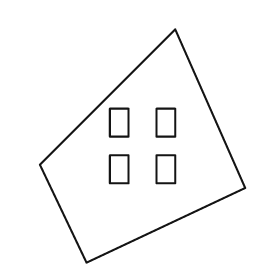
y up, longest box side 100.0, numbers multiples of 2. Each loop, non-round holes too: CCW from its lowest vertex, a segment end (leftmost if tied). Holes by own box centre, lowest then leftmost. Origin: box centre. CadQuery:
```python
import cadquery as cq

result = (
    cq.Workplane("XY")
    .moveTo(-24.0, -50.0)
    .lineTo(44.0, -18.0)
    .lineTo(14.0, 50.0)
    .lineTo(-44.0, -8.0)
    .close()
    .moveTo(-14.0, -16.0)
    .lineTo(-6.0, -16.0)
    .lineTo(-6.0, -4.0)
    .lineTo(-14.0, -4.0)
    .close()
    .moveTo(6.0, -16.0)
    .lineTo(14.0, -16.0)
    .lineTo(14.0, -4.0)
    .lineTo(6.0, -4.0)
    .close()
    .moveTo(-14.0, 4.0)
    .lineTo(-6.0, 4.0)
    .lineTo(-6.0, 16.0)
    .lineTo(-14.0, 16.0)
    .close()
    .moveTo(6.0, 4.0)
    .lineTo(14.0, 4.0)
    .lineTo(14.0, 16.0)
    .lineTo(6.0, 16.0)
    .close()
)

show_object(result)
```